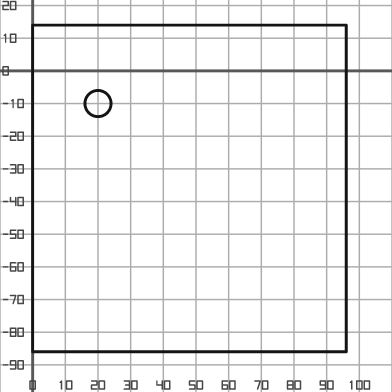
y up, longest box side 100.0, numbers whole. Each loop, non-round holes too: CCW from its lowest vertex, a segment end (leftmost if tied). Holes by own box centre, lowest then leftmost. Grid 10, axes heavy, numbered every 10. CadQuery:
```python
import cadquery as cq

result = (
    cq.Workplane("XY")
    .moveTo(0.0, -86.0)
    .lineTo(96.0, -86.0)
    .lineTo(96.0, 14.0)
    .lineTo(0.0, 14.0)
    .close()
    .moveTo(20.0, -10.0)
    .circle(4.0)
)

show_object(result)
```